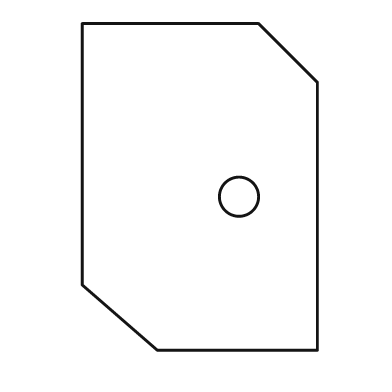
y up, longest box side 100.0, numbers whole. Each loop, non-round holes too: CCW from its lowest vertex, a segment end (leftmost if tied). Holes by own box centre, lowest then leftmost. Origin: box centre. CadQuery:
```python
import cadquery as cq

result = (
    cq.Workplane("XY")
    .moveTo(-13.0, -50.0)
    .lineTo(36.0, -50.0)
    .lineTo(36.0, 32.0)
    .lineTo(18.0, 50.0)
    .lineTo(-36.0, 50.0)
    .lineTo(-36.0, -30.0)
    .close()
    .moveTo(12.0, -3.0)
    .circle(6.0)
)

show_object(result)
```